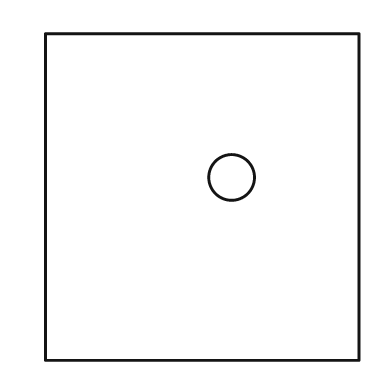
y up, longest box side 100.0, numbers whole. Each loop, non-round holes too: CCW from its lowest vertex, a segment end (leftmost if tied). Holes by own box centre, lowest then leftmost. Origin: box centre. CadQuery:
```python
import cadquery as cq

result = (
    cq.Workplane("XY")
    .moveTo(-48.0, -50.0)
    .lineTo(48.0, -50.0)
    .lineTo(48.0, 50.0)
    .lineTo(-48.0, 50.0)
    .close()
    .moveTo(9.0, 6.0)
    .circle(7.0)
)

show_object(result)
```